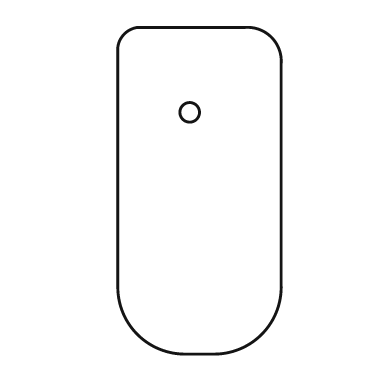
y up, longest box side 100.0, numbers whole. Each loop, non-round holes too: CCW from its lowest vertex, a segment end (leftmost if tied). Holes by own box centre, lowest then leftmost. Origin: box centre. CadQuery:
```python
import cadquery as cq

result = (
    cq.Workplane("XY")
    .moveTo(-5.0, -50.0)
    .lineTo(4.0, -50.0)
    .threePointArc((19.0, -44.0), (25.0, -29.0))
    .lineTo(25.0, 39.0)
    .threePointArc((22.0, 47.0), (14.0, 50.0))
    .lineTo(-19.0, 50.0)
    .threePointArc((-23.0, 48.0), (-25.0, 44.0))
    .lineTo(-25.0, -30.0)
    .threePointArc((-19.0, -44.0), (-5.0, -50.0))
    .close()
    .moveTo(-3.0, 24.0)
    .circle(3.0)
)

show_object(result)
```